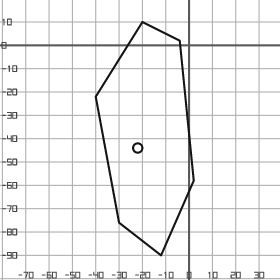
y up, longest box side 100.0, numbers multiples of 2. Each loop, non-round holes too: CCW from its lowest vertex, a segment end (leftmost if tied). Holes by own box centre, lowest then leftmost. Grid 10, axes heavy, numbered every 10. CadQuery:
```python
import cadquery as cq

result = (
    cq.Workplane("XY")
    .moveTo(-12.0, -90.0)
    .lineTo(2.0, -58.0)
    .lineTo(-4.0, 2.0)
    .lineTo(-20.0, 10.0)
    .lineTo(-40.0, -22.0)
    .lineTo(-30.0, -76.0)
    .close()
    .moveTo(-22.0, -44.0)
    .circle(2.0)
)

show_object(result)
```